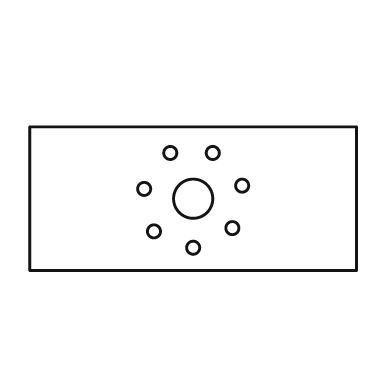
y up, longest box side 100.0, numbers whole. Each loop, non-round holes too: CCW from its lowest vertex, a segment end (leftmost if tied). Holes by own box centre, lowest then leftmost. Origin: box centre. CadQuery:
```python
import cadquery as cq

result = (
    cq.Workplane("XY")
    .moveTo(-50.0, -22.0)
    .lineTo(50.0, -22.0)
    .lineTo(50.0, 22.0)
    .lineTo(-50.0, 22.0)
    .close()
    .moveTo(0.0, -15.0)
    .circle(2.0)
    .moveTo(-12.0, -10.0)
    .circle(2.0)
    .moveTo(12.0, -9.0)
    .circle(2.0)
    .moveTo(0.0, 0.0)
    .circle(6.0)
    .moveTo(-15.0, 3.0)
    .circle(2.0)
    .moveTo(15.0, 4.0)
    .circle(2.0)
    .moveTo(-7.0, 14.0)
    .circle(2.0)
    .moveTo(6.0, 14.0)
    .circle(2.0)
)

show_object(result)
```